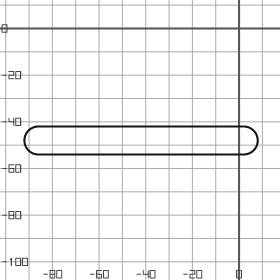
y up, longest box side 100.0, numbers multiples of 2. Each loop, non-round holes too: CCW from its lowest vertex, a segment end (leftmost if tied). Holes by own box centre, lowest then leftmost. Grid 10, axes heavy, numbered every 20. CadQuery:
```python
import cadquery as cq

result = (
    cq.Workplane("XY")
    .moveTo(-86.0, -54.0)
    .lineTo(2.0, -54.0)
    .threePointArc((8.0, -48.0), (2.0, -42.0))
    .lineTo(-86.0, -42.0)
    .threePointArc((-92.0, -48.0), (-86.0, -54.0))
    .close()
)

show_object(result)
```